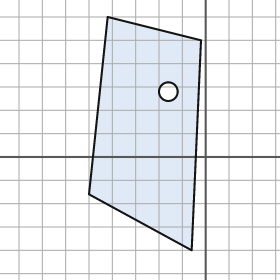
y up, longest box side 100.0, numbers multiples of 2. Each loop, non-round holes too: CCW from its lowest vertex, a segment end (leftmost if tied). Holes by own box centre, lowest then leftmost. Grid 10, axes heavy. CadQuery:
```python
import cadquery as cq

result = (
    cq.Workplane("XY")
    .moveTo(-6.0, -40.0)
    .lineTo(-2.0, 50.0)
    .lineTo(-42.0, 60.0)
    .lineTo(-50.0, -16.0)
    .close()
    .moveTo(-16.0, 28.0)
    .circle(4.0)
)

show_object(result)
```